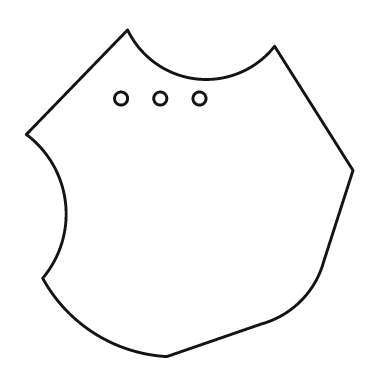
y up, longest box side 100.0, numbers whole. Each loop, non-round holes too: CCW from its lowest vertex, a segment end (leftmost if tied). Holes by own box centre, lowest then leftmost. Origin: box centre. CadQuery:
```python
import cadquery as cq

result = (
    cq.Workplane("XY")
    .moveTo(-7.0, -50.0)
    .lineTo(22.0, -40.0)
    .threePointArc((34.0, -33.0), (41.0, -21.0))
    .lineTo(50.0, 7.0)
    .lineTo(26.0, 45.0)
    .threePointArc((2.0, 35.0), (-19.0, 50.0))
    .lineTo(-50.0, 18.0)
    .threePointArc((-38.0, -3.0), (-45.0, -26.0))
    .threePointArc((-29.0, -43.0), (-7.0, -50.0))
    .close()
    .moveTo(-21.0, 29.0)
    .circle(2.0)
    .moveTo(-9.0, 29.0)
    .circle(2.0)
    .moveTo(3.0, 29.0)
    .circle(2.0)
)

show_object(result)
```